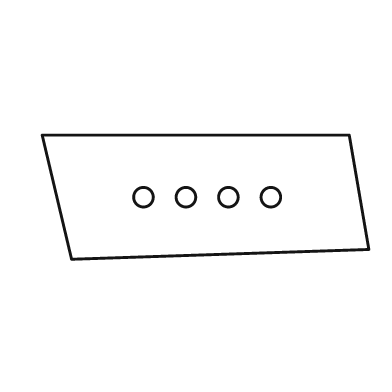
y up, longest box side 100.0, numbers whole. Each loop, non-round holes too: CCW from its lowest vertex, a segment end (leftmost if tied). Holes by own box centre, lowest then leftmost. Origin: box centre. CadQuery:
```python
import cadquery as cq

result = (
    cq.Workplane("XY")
    .moveTo(-41.0, -19.0)
    .lineTo(50.0, -16.0)
    .lineTo(44.0, 19.0)
    .lineTo(-50.0, 19.0)
    .close()
    .moveTo(-19.0, 0.0)
    .circle(3.0)
    .moveTo(-6.0, 0.0)
    .circle(3.0)
    .moveTo(7.0, 0.0)
    .circle(3.0)
    .moveTo(20.0, 0.0)
    .circle(3.0)
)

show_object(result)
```